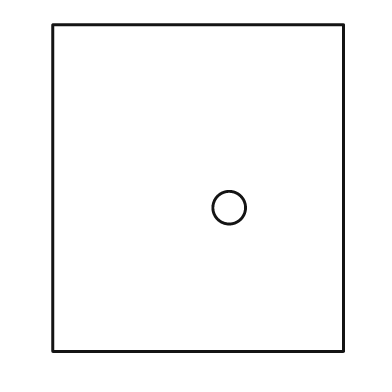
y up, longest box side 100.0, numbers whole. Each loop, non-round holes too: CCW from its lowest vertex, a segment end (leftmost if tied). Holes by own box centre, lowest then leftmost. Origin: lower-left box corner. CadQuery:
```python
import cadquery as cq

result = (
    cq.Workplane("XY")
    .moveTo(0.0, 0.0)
    .lineTo(89.0, 0.0)
    .lineTo(89.0, 100.0)
    .lineTo(0.0, 100.0)
    .close()
    .moveTo(54.0, 44.0)
    .circle(5.0)
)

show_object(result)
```